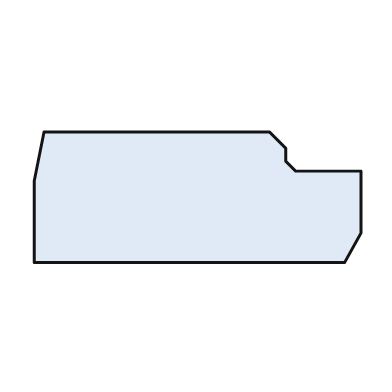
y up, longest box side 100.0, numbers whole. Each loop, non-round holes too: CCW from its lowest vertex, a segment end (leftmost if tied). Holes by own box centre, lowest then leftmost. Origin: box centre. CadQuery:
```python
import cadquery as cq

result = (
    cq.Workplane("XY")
    .moveTo(-50.0, -20.0)
    .lineTo(45.0, -20.0)
    .lineTo(50.0, -11.0)
    .lineTo(50.0, 8.0)
    .lineTo(30.0, 8.0)
    .lineTo(27.0, 11.0)
    .lineTo(27.0, 15.0)
    .lineTo(22.0, 20.0)
    .lineTo(-47.0, 20.0)
    .lineTo(-50.0, 5.0)
    .close()
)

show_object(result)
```